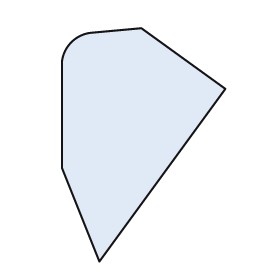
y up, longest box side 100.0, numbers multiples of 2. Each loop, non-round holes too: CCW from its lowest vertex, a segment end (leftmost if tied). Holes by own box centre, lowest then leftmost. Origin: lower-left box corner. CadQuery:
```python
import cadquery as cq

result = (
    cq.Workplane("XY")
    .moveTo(16.0, 0.0)
    .lineTo(70.0, 74.0)
    .lineTo(34.0, 100.0)
    .lineTo(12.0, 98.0)
    .threePointArc((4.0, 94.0), (0.0, 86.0))
    .lineTo(0.0, 40.0)
    .close()
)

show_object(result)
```